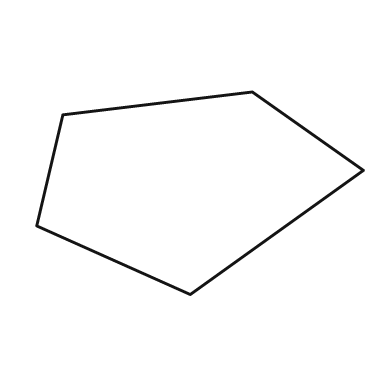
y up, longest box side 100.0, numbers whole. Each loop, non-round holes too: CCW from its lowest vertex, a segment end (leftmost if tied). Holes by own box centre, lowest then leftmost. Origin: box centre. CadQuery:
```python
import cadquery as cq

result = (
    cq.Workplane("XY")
    .moveTo(-3.0, -31.0)
    .lineTo(50.0, 7.0)
    .lineTo(16.0, 31.0)
    .lineTo(-42.0, 24.0)
    .lineTo(-50.0, -10.0)
    .close()
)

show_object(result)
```